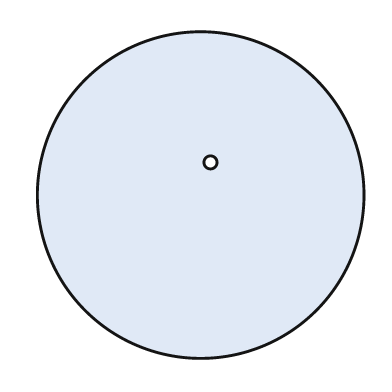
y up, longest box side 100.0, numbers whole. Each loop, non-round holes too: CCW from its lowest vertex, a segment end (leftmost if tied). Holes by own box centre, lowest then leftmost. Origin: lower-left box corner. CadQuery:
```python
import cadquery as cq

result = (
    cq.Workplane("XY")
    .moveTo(50.0, 50.0)
    .circle(50.0)
    .moveTo(53.0, 60.0)
    .circle(2.0)
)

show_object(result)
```